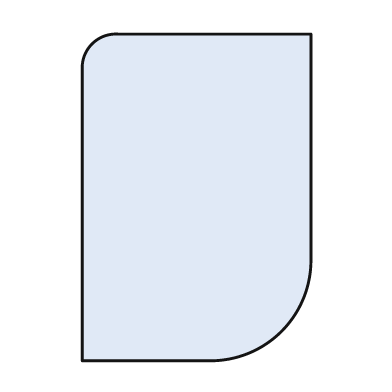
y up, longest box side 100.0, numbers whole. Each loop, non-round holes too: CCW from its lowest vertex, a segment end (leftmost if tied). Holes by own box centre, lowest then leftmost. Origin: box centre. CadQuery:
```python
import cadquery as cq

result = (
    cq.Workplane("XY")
    .moveTo(-35.0, -50.0)
    .lineTo(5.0, -50.0)
    .threePointArc((26.0, -41.0), (35.0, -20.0))
    .lineTo(35.0, 50.0)
    .lineTo(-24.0, 50.0)
    .threePointArc((-32.0, 47.0), (-35.0, 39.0))
    .close()
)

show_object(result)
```